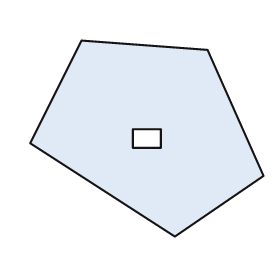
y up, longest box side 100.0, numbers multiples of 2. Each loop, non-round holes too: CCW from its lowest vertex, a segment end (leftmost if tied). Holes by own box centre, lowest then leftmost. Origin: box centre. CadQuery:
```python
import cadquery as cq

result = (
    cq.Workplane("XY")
    .moveTo(12.0, -42.0)
    .lineTo(50.0, -16.0)
    .lineTo(26.0, 38.0)
    .lineTo(-28.0, 42.0)
    .lineTo(-50.0, -2.0)
    .close()
    .moveTo(-6.0, -4.0)
    .lineTo(6.0, -4.0)
    .lineTo(6.0, 4.0)
    .lineTo(-6.0, 4.0)
    .close()
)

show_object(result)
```